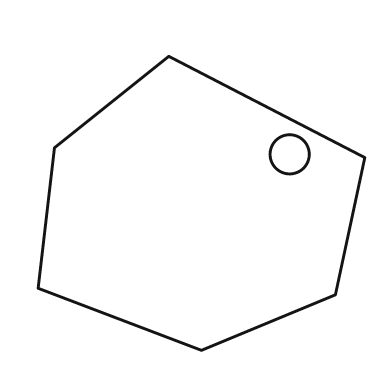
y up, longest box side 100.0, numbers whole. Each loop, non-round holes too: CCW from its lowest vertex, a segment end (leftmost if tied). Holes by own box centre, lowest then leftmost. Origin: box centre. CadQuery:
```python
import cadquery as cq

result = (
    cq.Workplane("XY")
    .moveTo(0.0, -45.0)
    .lineTo(41.0, -28.0)
    .lineTo(50.0, 14.0)
    .lineTo(-10.0, 45.0)
    .lineTo(-45.0, 17.0)
    .lineTo(-50.0, -26.0)
    .close()
    .moveTo(27.0, 15.0)
    .circle(6.0)
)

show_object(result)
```